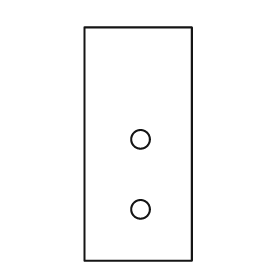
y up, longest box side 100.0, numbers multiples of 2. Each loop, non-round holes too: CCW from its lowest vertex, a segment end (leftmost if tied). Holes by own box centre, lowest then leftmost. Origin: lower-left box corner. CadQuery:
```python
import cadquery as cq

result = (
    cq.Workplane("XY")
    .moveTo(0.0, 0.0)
    .lineTo(46.0, 0.0)
    .lineTo(46.0, 100.0)
    .lineTo(0.0, 100.0)
    .close()
    .moveTo(24.0, 22.0)
    .circle(4.0)
    .moveTo(24.0, 52.0)
    .circle(4.0)
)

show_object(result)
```